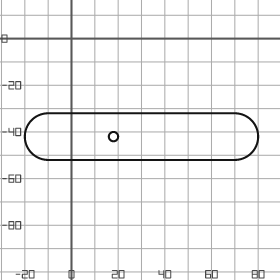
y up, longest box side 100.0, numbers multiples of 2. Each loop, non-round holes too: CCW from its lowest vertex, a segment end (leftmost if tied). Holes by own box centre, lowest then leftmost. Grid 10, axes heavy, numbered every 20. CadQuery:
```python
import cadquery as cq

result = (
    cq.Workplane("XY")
    .moveTo(-10.0, -52.0)
    .lineTo(70.0, -52.0)
    .threePointArc((80.0, -42.0), (70.0, -32.0))
    .lineTo(-10.0, -32.0)
    .threePointArc((-20.0, -42.0), (-10.0, -52.0))
    .close()
    .moveTo(18.0, -42.0)
    .circle(2.0)
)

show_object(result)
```